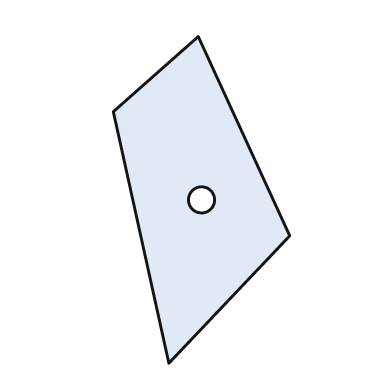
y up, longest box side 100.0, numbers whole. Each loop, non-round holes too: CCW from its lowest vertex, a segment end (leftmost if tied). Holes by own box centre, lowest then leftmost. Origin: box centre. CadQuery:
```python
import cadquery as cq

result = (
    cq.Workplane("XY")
    .moveTo(-10.0, -50.0)
    .lineTo(27.0, -11.0)
    .lineTo(-1.0, 50.0)
    .lineTo(-27.0, 27.0)
    .close()
    .moveTo(0.0, 0.0)
    .circle(4.0)
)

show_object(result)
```